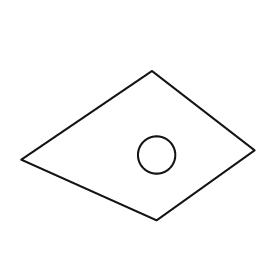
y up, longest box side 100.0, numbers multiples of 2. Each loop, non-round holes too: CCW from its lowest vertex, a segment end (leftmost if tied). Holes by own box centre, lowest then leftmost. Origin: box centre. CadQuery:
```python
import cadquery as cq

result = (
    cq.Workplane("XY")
    .moveTo(8.0, -32.0)
    .lineTo(50.0, -2.0)
    .lineTo(6.0, 32.0)
    .lineTo(-50.0, -6.0)
    .close()
    .moveTo(8.0, -4.0)
    .circle(8.0)
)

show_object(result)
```